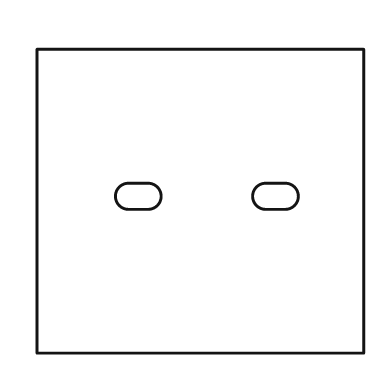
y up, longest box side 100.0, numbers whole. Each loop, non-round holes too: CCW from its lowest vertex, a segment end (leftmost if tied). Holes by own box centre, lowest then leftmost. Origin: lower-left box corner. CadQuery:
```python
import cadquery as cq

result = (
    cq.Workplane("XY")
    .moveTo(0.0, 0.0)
    .lineTo(100.0, 0.0)
    .lineTo(100.0, 93.0)
    .lineTo(0.0, 93.0)
    .close()
    .moveTo(28.0, 44.0)
    .lineTo(34.0, 44.0)
    .threePointArc((38.0, 48.0), (34.0, 52.0))
    .lineTo(28.0, 52.0)
    .threePointArc((24.0, 48.0), (28.0, 44.0))
    .close()
    .moveTo(70.0, 44.0)
    .lineTo(76.0, 44.0)
    .threePointArc((80.0, 48.0), (76.0, 52.0))
    .lineTo(70.0, 52.0)
    .threePointArc((66.0, 48.0), (70.0, 44.0))
    .close()
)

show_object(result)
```